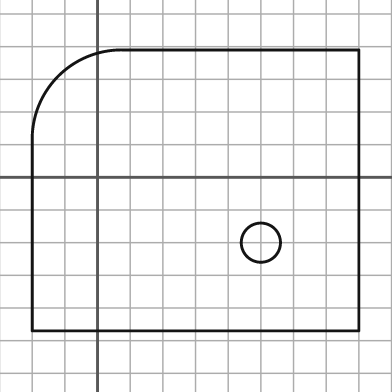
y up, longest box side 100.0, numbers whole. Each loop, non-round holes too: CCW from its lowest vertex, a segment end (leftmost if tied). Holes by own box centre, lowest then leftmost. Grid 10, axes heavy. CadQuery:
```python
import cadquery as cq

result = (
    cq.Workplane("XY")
    .moveTo(-20.0, -47.0)
    .lineTo(80.0, -47.0)
    .lineTo(80.0, 39.0)
    .lineTo(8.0, 39.0)
    .threePointArc((-12.0, 31.0), (-20.0, 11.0))
    .close()
    .moveTo(50.0, -20.0)
    .circle(6.0)
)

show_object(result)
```